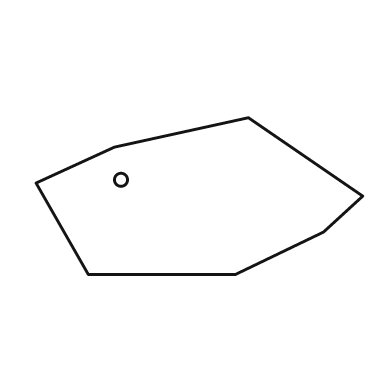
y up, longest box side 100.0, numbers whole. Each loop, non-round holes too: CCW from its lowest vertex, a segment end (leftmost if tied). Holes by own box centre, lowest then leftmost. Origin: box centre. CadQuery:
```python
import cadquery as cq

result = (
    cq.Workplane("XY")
    .moveTo(-34.0, -24.0)
    .lineTo(11.0, -24.0)
    .lineTo(38.0, -11.0)
    .lineTo(50.0, 0.0)
    .lineTo(15.0, 24.0)
    .lineTo(-26.0, 15.0)
    .lineTo(-50.0, 4.0)
    .close()
    .moveTo(-24.0, 5.0)
    .circle(2.0)
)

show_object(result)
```